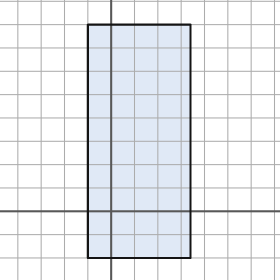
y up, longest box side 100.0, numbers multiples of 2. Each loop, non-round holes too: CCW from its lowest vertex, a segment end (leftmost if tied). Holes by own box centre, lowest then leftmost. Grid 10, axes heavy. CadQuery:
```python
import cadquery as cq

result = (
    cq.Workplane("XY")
    .moveTo(-10.0, -20.0)
    .lineTo(34.0, -20.0)
    .lineTo(34.0, 80.0)
    .lineTo(-10.0, 80.0)
    .close()
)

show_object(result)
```